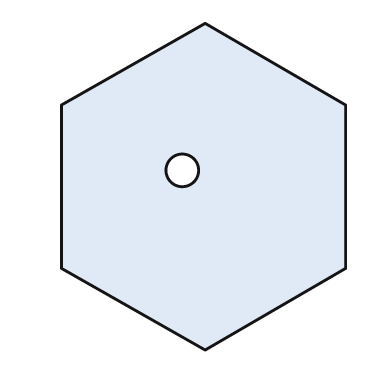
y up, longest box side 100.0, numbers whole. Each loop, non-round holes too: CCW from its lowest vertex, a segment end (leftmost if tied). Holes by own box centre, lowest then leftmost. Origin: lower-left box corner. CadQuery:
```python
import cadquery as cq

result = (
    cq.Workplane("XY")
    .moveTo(44.0, 0.0)
    .lineTo(87.0, 25.0)
    .lineTo(87.0, 75.0)
    .lineTo(44.0, 100.0)
    .lineTo(0.0, 75.0)
    .lineTo(0.0, 25.0)
    .close()
    .moveTo(37.0, 55.0)
    .circle(5.0)
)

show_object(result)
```